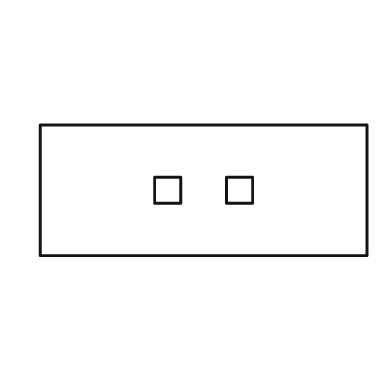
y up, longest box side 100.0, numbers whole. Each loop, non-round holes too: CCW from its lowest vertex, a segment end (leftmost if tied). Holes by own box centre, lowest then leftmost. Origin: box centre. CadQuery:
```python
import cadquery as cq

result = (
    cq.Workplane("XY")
    .moveTo(-50.0, -20.0)
    .lineTo(50.0, -20.0)
    .lineTo(50.0, 20.0)
    .lineTo(-50.0, 20.0)
    .close()
    .moveTo(-15.0, -4.0)
    .lineTo(-7.0, -4.0)
    .lineTo(-7.0, 4.0)
    .lineTo(-15.0, 4.0)
    .close()
    .moveTo(7.0, -4.0)
    .lineTo(15.0, -4.0)
    .lineTo(15.0, 4.0)
    .lineTo(7.0, 4.0)
    .close()
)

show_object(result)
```